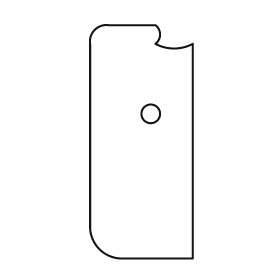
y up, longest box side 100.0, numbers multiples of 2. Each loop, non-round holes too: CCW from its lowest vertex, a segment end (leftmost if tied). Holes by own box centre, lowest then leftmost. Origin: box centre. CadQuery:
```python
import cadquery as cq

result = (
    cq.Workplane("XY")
    .moveTo(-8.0, -50.0)
    .lineTo(22.0, -50.0)
    .lineTo(22.0, 42.0)
    .threePointArc((14.0, 40.0), (6.0, 42.0))
    .threePointArc((8.0, 46.0), (6.0, 50.0))
    .lineTo(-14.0, 50.0)
    .threePointArc((-20.0, 48.0), (-22.0, 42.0))
    .lineTo(-22.0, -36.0)
    .threePointArc((-18.0, -46.0), (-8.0, -50.0))
    .close()
    .moveTo(4.0, 12.0)
    .circle(4.0)
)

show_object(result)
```